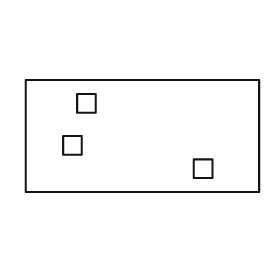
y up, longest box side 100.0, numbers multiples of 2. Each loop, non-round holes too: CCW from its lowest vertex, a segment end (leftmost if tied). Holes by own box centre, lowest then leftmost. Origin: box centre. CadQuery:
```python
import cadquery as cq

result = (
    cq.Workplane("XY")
    .moveTo(-50.0, -24.0)
    .lineTo(50.0, -24.0)
    .lineTo(50.0, 24.0)
    .lineTo(-50.0, 24.0)
    .close()
    .moveTo(22.0, -18.0)
    .lineTo(30.0, -18.0)
    .lineTo(30.0, -10.0)
    .lineTo(22.0, -10.0)
    .close()
    .moveTo(-34.0, -8.0)
    .lineTo(-26.0, -8.0)
    .lineTo(-26.0, 0.0)
    .lineTo(-34.0, 0.0)
    .close()
    .moveTo(-28.0, 10.0)
    .lineTo(-20.0, 10.0)
    .lineTo(-20.0, 18.0)
    .lineTo(-28.0, 18.0)
    .close()
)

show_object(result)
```